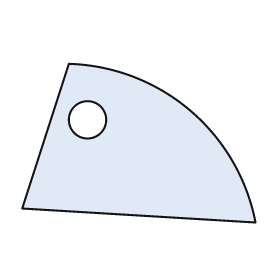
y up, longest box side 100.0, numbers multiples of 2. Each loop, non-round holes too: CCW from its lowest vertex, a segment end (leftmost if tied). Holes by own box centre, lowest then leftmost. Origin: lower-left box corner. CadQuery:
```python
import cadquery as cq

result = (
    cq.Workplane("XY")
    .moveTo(100.0, 0.0)
    .threePointArc((72.0, 48.0), (20.0, 68.0))
    .lineTo(0.0, 6.0)
    .close()
    .moveTo(28.0, 44.0)
    .circle(8.0)
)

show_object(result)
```